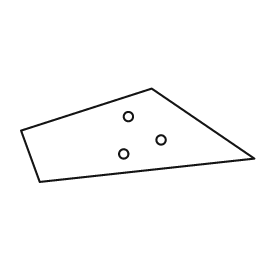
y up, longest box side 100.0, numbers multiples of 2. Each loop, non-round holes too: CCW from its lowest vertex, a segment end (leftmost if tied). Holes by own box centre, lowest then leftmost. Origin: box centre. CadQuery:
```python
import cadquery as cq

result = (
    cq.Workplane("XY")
    .moveTo(-42.0, -20.0)
    .lineTo(50.0, -10.0)
    .lineTo(6.0, 20.0)
    .lineTo(-50.0, 2.0)
    .close()
    .moveTo(-6.0, -8.0)
    .circle(2.0)
    .moveTo(10.0, -2.0)
    .circle(2.0)
    .moveTo(-4.0, 8.0)
    .circle(2.0)
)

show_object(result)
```